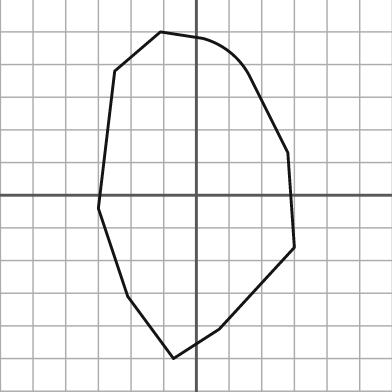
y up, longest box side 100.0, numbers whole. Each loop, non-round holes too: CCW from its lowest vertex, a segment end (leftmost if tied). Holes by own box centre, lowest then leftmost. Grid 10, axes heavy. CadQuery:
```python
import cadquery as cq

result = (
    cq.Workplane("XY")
    .moveTo(-7.0, -50.0)
    .lineTo(7.0, -41.0)
    .lineTo(30.0, -16.0)
    .lineTo(28.0, 13.0)
    .lineTo(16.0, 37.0)
    .threePointArc((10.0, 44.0), (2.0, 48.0))
    .lineTo(-11.0, 50.0)
    .lineTo(-25.0, 38.0)
    .lineTo(-30.0, -4.0)
    .lineTo(-21.0, -31.0)
    .close()
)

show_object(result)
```